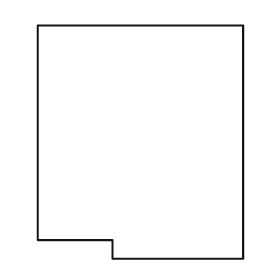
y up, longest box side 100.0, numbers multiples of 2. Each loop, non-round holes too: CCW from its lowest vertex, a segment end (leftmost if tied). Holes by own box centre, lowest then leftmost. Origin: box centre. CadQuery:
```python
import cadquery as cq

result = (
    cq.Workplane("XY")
    .moveTo(-12.0, -50.0)
    .lineTo(44.0, -50.0)
    .lineTo(44.0, 50.0)
    .lineTo(-44.0, 50.0)
    .lineTo(-44.0, -42.0)
    .lineTo(-12.0, -42.0)
    .close()
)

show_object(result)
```